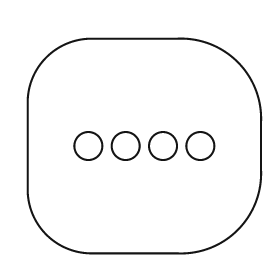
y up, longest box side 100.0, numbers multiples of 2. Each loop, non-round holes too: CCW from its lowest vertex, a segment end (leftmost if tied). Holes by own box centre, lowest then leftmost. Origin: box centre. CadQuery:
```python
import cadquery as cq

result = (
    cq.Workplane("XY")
    .moveTo(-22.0, -46.0)
    .lineTo(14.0, -46.0)
    .threePointArc((40.0, -36.0), (50.0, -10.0))
    .lineTo(50.0, 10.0)
    .threePointArc((40.0, 36.0), (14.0, 46.0))
    .lineTo(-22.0, 46.0)
    .threePointArc((-42.0, 38.0), (-50.0, 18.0))
    .lineTo(-50.0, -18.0)
    .threePointArc((-42.0, -38.0), (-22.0, -46.0))
    .close()
    .moveTo(-24.0, 0.0)
    .circle(6.0)
    .moveTo(-8.0, 0.0)
    .circle(6.0)
    .moveTo(8.0, 0.0)
    .circle(6.0)
    .moveTo(24.0, 0.0)
    .circle(6.0)
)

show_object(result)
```